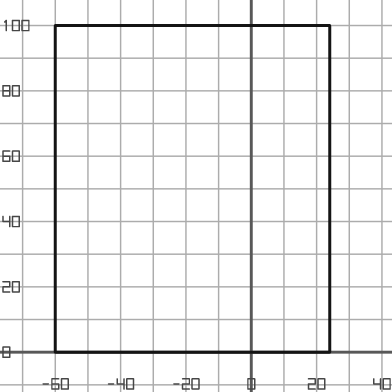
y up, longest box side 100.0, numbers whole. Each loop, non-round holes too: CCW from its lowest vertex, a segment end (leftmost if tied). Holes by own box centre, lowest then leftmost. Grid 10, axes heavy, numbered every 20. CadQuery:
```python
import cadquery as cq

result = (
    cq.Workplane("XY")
    .moveTo(-60.0, 0.0)
    .lineTo(24.0, 0.0)
    .lineTo(24.0, 100.0)
    .lineTo(-60.0, 100.0)
    .close()
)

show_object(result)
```